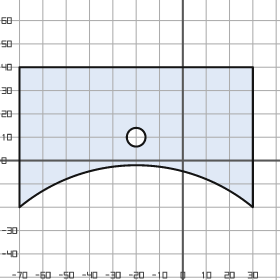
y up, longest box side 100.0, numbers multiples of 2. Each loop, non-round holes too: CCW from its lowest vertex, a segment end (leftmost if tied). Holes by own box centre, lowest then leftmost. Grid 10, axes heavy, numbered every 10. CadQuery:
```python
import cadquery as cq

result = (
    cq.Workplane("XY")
    .moveTo(-70.0, -20.0)
    .threePointArc((-20.0, -2.0), (30.0, -20.0))
    .lineTo(30.0, 40.0)
    .lineTo(-70.0, 40.0)
    .close()
    .moveTo(-20.0, 10.0)
    .circle(4.0)
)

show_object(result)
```